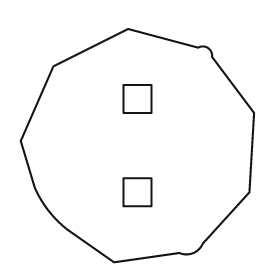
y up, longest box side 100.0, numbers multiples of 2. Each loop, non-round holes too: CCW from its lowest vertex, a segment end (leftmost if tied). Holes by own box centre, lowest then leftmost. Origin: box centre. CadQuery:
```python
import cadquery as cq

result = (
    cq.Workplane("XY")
    .moveTo(-10.0, -50.0)
    .lineTo(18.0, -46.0)
    .threePointArc((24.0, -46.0), (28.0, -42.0))
    .lineTo(48.0, -20.0)
    .lineTo(50.0, 14.0)
    .lineTo(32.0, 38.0)
    .threePointArc((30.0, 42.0), (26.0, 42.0))
    .lineTo(-4.0, 50.0)
    .lineTo(-36.0, 34.0)
    .lineTo(-50.0, 2.0)
    .lineTo(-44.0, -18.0)
    .threePointArc((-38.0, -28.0), (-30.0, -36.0))
    .close()
    .moveTo(-6.0, -26.0)
    .lineTo(6.0, -26.0)
    .lineTo(6.0, -14.0)
    .lineTo(-6.0, -14.0)
    .close()
    .moveTo(-6.0, 14.0)
    .lineTo(6.0, 14.0)
    .lineTo(6.0, 26.0)
    .lineTo(-6.0, 26.0)
    .close()
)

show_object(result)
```